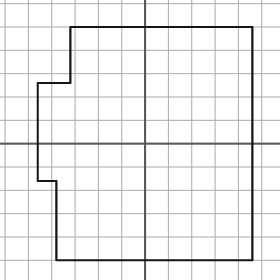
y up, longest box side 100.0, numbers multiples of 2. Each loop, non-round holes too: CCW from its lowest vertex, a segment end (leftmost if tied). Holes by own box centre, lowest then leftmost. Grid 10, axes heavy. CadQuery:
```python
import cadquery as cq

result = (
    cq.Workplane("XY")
    .moveTo(-38.0, -50.0)
    .lineTo(46.0, -50.0)
    .lineTo(46.0, 50.0)
    .lineTo(-32.0, 50.0)
    .lineTo(-32.0, 26.0)
    .lineTo(-46.0, 26.0)
    .lineTo(-46.0, -16.0)
    .lineTo(-38.0, -16.0)
    .close()
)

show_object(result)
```